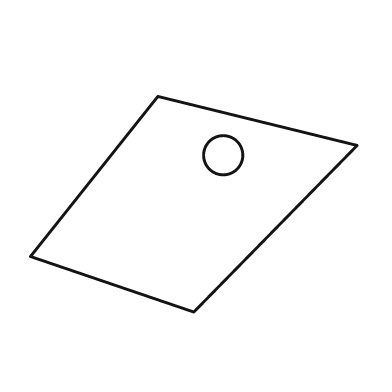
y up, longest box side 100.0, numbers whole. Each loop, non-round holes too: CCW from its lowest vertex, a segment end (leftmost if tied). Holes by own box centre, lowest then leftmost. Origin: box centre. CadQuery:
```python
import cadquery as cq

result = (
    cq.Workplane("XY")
    .moveTo(0.0, -33.0)
    .lineTo(50.0, 18.0)
    .lineTo(-11.0, 33.0)
    .lineTo(-50.0, -16.0)
    .close()
    .moveTo(9.0, 15.0)
    .circle(6.0)
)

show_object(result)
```